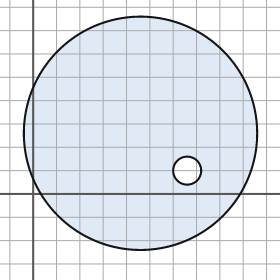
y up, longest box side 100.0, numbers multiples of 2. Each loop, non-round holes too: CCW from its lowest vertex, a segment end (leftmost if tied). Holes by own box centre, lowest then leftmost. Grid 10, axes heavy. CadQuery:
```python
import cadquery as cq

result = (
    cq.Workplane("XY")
    .moveTo(46.0, 26.0)
    .circle(50.0)
    .moveTo(66.0, 10.0)
    .circle(6.0)
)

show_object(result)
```